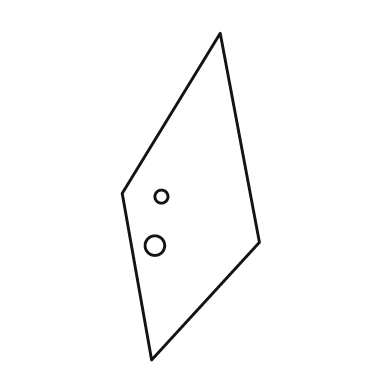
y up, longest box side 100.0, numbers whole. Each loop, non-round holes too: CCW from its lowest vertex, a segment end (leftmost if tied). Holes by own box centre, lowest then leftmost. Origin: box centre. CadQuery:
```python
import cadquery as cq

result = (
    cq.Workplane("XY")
    .moveTo(-12.0, -50.0)
    .lineTo(21.0, -14.0)
    .lineTo(9.0, 50.0)
    .lineTo(-21.0, 1.0)
    .close()
    .moveTo(-11.0, -15.0)
    .circle(3.0)
    .moveTo(-9.0, 0.0)
    .circle(2.0)
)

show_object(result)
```